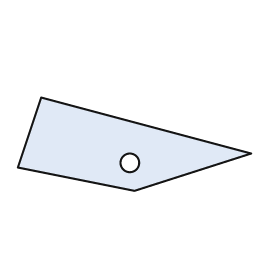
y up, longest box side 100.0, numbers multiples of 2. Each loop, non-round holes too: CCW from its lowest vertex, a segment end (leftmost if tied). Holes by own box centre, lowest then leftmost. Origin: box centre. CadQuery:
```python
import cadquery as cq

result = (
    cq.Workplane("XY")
    .moveTo(0.0, -20.0)
    .lineTo(50.0, -4.0)
    .lineTo(-40.0, 20.0)
    .lineTo(-50.0, -10.0)
    .close()
    .moveTo(-2.0, -8.0)
    .circle(4.0)
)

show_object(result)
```